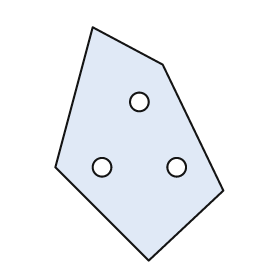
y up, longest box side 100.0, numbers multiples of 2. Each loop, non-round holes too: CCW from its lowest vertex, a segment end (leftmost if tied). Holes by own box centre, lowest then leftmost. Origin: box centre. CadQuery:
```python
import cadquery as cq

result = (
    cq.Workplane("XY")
    .moveTo(4.0, -50.0)
    .lineTo(36.0, -20.0)
    .lineTo(10.0, 34.0)
    .lineTo(-20.0, 50.0)
    .lineTo(-36.0, -10.0)
    .close()
    .moveTo(-16.0, -10.0)
    .circle(4.0)
    .moveTo(16.0, -10.0)
    .circle(4.0)
    .moveTo(0.0, 18.0)
    .circle(4.0)
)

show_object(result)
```